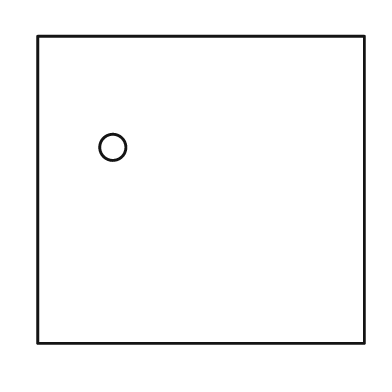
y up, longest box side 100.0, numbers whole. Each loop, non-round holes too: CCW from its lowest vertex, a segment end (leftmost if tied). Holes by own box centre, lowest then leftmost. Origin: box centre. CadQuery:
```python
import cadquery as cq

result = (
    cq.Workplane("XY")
    .moveTo(-50.0, -47.0)
    .lineTo(50.0, -47.0)
    .lineTo(50.0, 47.0)
    .lineTo(-50.0, 47.0)
    .close()
    .moveTo(-27.0, 13.0)
    .circle(4.0)
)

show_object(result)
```